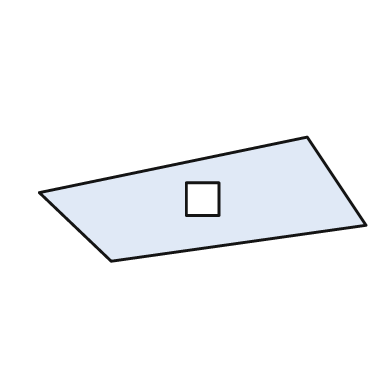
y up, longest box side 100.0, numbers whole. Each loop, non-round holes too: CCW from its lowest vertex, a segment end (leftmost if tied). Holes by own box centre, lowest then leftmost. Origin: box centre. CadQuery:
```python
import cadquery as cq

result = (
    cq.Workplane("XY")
    .moveTo(-28.0, -19.0)
    .lineTo(50.0, -8.0)
    .lineTo(32.0, 19.0)
    .lineTo(-50.0, 2.0)
    .close()
    .moveTo(-5.0, -5.0)
    .lineTo(5.0, -5.0)
    .lineTo(5.0, 5.0)
    .lineTo(-5.0, 5.0)
    .close()
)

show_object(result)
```